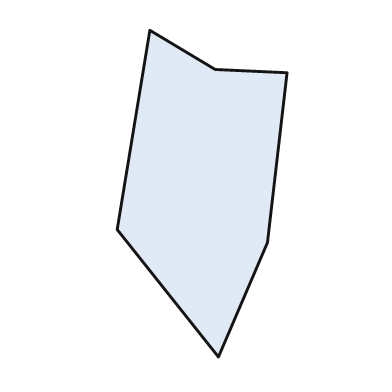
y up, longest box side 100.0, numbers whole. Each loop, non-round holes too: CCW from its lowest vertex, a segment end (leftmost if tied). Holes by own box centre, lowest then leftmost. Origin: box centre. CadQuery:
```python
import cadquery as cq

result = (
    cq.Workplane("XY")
    .moveTo(5.0, -50.0)
    .lineTo(20.0, -15.0)
    .lineTo(26.0, 37.0)
    .lineTo(4.0, 38.0)
    .lineTo(-16.0, 50.0)
    .lineTo(-26.0, -11.0)
    .close()
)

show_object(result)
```